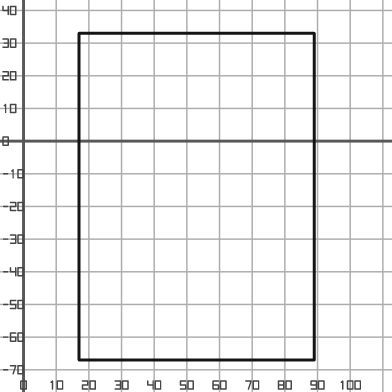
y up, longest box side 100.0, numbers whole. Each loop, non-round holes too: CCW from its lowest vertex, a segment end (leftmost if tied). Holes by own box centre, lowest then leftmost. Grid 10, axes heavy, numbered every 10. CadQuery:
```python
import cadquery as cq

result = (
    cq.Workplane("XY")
    .moveTo(17.0, -67.0)
    .lineTo(89.0, -67.0)
    .lineTo(89.0, 33.0)
    .lineTo(17.0, 33.0)
    .close()
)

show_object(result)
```